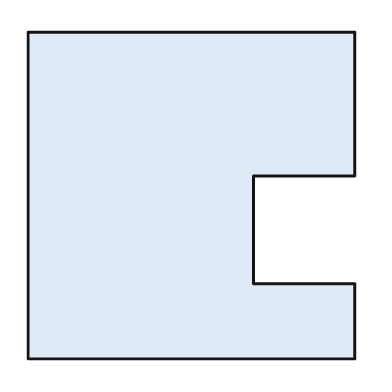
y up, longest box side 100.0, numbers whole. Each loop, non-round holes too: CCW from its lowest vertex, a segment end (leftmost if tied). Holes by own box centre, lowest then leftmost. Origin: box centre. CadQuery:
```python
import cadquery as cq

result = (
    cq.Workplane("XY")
    .moveTo(-50.0, -50.0)
    .lineTo(50.0, -50.0)
    .lineTo(50.0, -27.0)
    .lineTo(19.0, -27.0)
    .lineTo(19.0, 6.0)
    .lineTo(50.0, 6.0)
    .lineTo(50.0, 50.0)
    .lineTo(-50.0, 50.0)
    .close()
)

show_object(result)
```